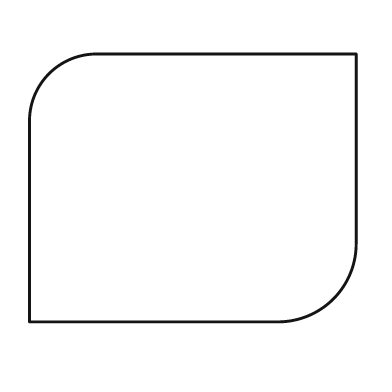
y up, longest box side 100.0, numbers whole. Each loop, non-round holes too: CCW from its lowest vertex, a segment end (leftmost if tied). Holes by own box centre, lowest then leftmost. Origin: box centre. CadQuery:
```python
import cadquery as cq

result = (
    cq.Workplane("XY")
    .moveTo(-50.0, -41.0)
    .lineTo(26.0, -41.0)
    .threePointArc((43.0, -34.0), (50.0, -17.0))
    .lineTo(50.0, 41.0)
    .lineTo(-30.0, 41.0)
    .threePointArc((-44.0, 35.0), (-50.0, 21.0))
    .close()
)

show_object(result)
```